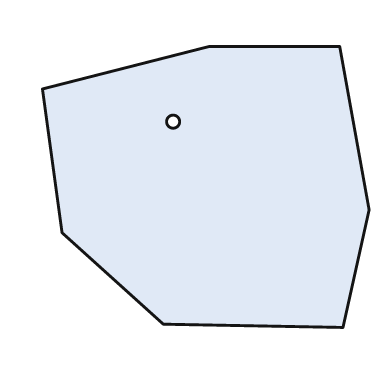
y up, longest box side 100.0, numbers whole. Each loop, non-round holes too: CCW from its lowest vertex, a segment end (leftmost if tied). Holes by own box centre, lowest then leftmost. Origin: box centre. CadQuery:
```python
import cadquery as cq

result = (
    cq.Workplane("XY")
    .moveTo(42.0, -43.0)
    .lineTo(50.0, -7.0)
    .lineTo(41.0, 43.0)
    .lineTo(1.0, 43.0)
    .lineTo(-50.0, 30.0)
    .lineTo(-44.0, -14.0)
    .lineTo(-13.0, -42.0)
    .close()
    .moveTo(-10.0, 20.0)
    .circle(2.0)
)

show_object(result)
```